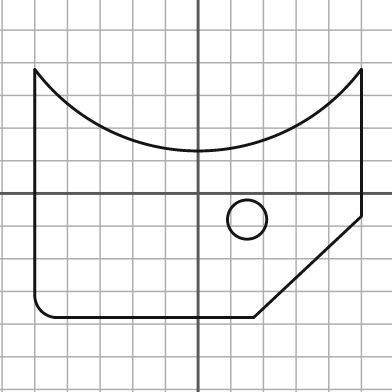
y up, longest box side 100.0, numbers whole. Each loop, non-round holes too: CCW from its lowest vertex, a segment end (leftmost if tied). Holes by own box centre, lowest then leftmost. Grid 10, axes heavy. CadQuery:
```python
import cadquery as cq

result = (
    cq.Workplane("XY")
    .moveTo(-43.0, -38.0)
    .lineTo(17.0, -38.0)
    .lineTo(50.0, -7.0)
    .lineTo(50.0, 38.0)
    .threePointArc((0.0, 13.0), (-50.0, 38.0))
    .lineTo(-50.0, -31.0)
    .threePointArc((-48.0, -36.0), (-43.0, -38.0))
    .close()
    .moveTo(15.0, -8.0)
    .circle(6.0)
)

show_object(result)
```